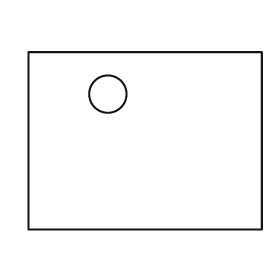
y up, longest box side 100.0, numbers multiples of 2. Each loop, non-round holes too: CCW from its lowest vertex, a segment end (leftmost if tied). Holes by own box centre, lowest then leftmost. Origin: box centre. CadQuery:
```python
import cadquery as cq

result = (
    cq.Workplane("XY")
    .moveTo(-50.0, -38.0)
    .lineTo(50.0, -38.0)
    .lineTo(50.0, 38.0)
    .lineTo(-50.0, 38.0)
    .close()
    .moveTo(-16.0, 20.0)
    .circle(8.0)
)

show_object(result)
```